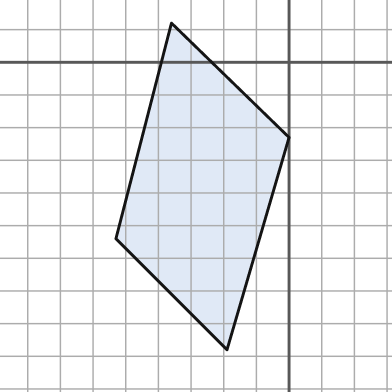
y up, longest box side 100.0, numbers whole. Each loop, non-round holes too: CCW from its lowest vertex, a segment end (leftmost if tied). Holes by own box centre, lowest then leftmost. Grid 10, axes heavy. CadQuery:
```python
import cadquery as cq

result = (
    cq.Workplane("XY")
    .moveTo(-19.0, -88.0)
    .lineTo(0.0, -23.0)
    .lineTo(-36.0, 12.0)
    .lineTo(-53.0, -54.0)
    .close()
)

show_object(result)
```